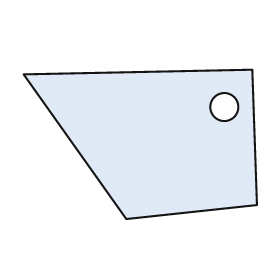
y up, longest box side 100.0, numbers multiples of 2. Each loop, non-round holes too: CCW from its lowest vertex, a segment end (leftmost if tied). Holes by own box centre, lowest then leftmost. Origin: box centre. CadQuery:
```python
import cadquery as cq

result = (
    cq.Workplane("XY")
    .moveTo(-6.0, -32.0)
    .lineTo(50.0, -26.0)
    .lineTo(48.0, 32.0)
    .lineTo(-50.0, 30.0)
    .close()
    .moveTo(36.0, 16.0)
    .circle(6.0)
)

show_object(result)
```